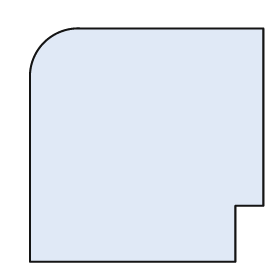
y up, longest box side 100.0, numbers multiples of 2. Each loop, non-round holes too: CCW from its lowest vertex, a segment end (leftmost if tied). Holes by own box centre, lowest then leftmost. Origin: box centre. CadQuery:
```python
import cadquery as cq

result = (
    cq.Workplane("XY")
    .moveTo(-50.0, -50.0)
    .lineTo(38.0, -50.0)
    .lineTo(38.0, -26.0)
    .lineTo(50.0, -26.0)
    .lineTo(50.0, 50.0)
    .lineTo(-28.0, 50.0)
    .threePointArc((-44.0, 44.0), (-50.0, 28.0))
    .close()
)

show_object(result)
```